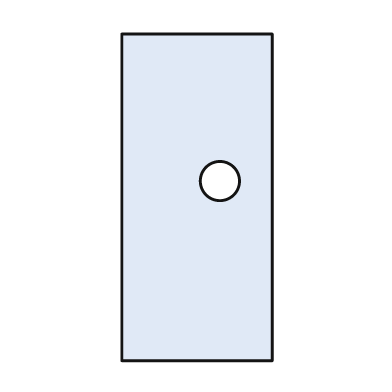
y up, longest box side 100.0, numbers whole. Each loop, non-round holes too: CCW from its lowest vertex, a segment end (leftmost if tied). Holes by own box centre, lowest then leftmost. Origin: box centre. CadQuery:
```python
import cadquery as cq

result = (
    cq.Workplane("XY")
    .moveTo(-23.0, -50.0)
    .lineTo(23.0, -50.0)
    .lineTo(23.0, 50.0)
    .lineTo(-23.0, 50.0)
    .close()
    .moveTo(7.0, 5.0)
    .circle(6.0)
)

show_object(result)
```